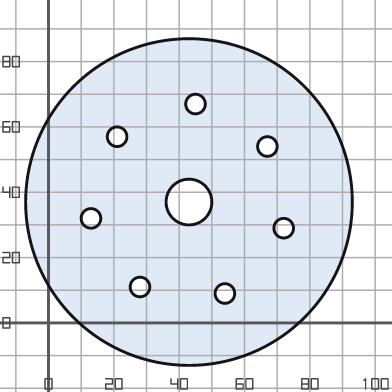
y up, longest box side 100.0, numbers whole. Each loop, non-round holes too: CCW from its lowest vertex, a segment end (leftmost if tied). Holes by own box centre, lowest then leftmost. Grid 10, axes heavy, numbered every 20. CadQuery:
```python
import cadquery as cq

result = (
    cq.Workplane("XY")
    .moveTo(43.0, 37.0)
    .circle(50.0)
    .moveTo(54.0, 9.0)
    .circle(3.0)
    .moveTo(28.0, 11.0)
    .circle(3.0)
    .moveTo(72.0, 29.0)
    .circle(3.0)
    .moveTo(13.0, 32.0)
    .circle(3.0)
    .moveTo(43.0, 37.0)
    .circle(7.0)
    .moveTo(67.0, 54.0)
    .circle(3.0)
    .moveTo(21.0, 57.0)
    .circle(3.0)
    .moveTo(45.0, 67.0)
    .circle(3.0)
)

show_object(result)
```